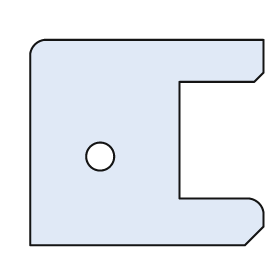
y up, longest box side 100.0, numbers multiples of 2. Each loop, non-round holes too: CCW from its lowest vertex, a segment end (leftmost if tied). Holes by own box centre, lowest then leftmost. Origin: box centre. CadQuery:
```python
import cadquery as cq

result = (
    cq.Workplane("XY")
    .moveTo(-50.0, -44.0)
    .lineTo(42.0, -44.0)
    .lineTo(50.0, -36.0)
    .lineTo(50.0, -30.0)
    .threePointArc((48.0, -26.0), (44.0, -24.0))
    .lineTo(14.0, -24.0)
    .lineTo(14.0, 26.0)
    .lineTo(46.0, 26.0)
    .lineTo(50.0, 30.0)
    .lineTo(50.0, 44.0)
    .lineTo(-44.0, 44.0)
    .threePointArc((-48.0, 42.0), (-50.0, 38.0))
    .close()
    .moveTo(-20.0, -6.0)
    .circle(6.0)
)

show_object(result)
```